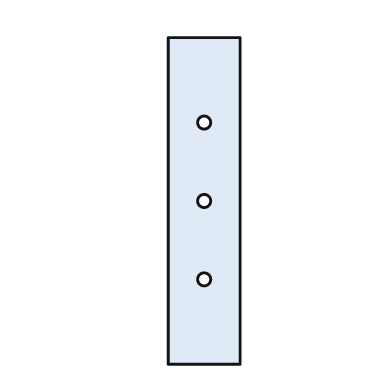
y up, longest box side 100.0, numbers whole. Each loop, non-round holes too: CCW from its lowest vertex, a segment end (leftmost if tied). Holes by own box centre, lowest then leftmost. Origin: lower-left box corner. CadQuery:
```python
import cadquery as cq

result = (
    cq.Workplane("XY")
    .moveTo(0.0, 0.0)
    .lineTo(22.0, 0.0)
    .lineTo(22.0, 100.0)
    .lineTo(0.0, 100.0)
    .close()
    .moveTo(11.0, 26.0)
    .circle(2.0)
    .moveTo(11.0, 50.0)
    .circle(2.0)
    .moveTo(11.0, 74.0)
    .circle(2.0)
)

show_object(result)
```